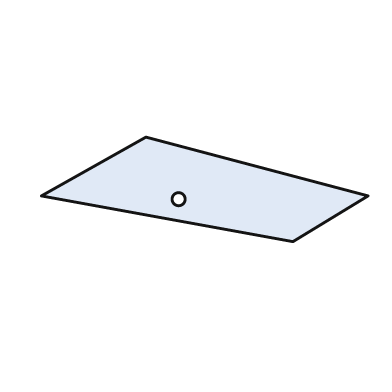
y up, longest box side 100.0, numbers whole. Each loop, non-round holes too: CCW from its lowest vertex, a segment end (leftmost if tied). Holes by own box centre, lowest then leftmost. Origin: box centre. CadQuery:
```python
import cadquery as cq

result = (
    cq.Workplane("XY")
    .moveTo(27.0, -16.0)
    .lineTo(50.0, -2.0)
    .lineTo(-18.0, 16.0)
    .lineTo(-50.0, -2.0)
    .close()
    .moveTo(-8.0, -3.0)
    .circle(2.0)
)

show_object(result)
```